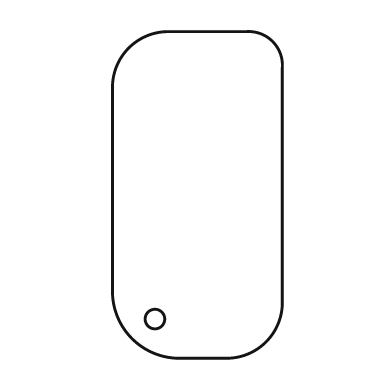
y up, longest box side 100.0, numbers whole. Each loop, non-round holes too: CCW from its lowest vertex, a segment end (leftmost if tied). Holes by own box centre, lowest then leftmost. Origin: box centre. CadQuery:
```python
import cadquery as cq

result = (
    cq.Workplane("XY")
    .moveTo(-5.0, -50.0)
    .lineTo(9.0, -50.0)
    .threePointArc((21.0, -45.0), (26.0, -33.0))
    .lineTo(26.0, 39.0)
    .threePointArc((23.0, 47.0), (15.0, 50.0))
    .lineTo(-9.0, 50.0)
    .threePointArc((-21.0, 45.0), (-26.0, 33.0))
    .lineTo(-26.0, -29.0)
    .threePointArc((-20.0, -44.0), (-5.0, -50.0))
    .close()
    .moveTo(-13.0, -38.0)
    .circle(3.0)
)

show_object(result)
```